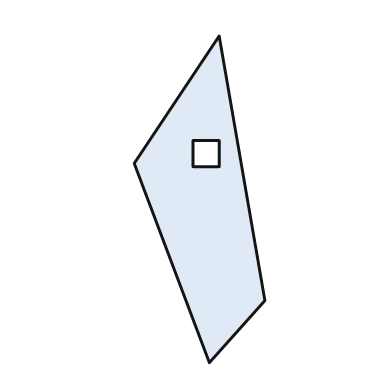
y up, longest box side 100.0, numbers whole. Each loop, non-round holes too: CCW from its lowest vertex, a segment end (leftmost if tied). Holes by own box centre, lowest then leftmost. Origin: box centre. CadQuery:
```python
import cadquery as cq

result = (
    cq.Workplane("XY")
    .moveTo(3.0, -50.0)
    .lineTo(20.0, -31.0)
    .lineTo(6.0, 50.0)
    .lineTo(-20.0, 11.0)
    .close()
    .moveTo(-2.0, 10.0)
    .lineTo(6.0, 10.0)
    .lineTo(6.0, 18.0)
    .lineTo(-2.0, 18.0)
    .close()
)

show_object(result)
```